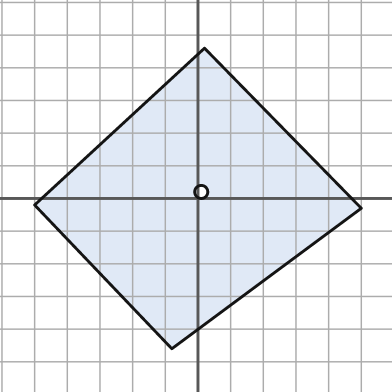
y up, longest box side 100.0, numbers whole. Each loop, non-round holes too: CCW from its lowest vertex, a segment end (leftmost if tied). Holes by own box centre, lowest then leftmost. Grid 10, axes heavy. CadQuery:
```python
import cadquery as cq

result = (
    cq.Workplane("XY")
    .moveTo(-8.0, -46.0)
    .lineTo(50.0, -3.0)
    .lineTo(2.0, 46.0)
    .lineTo(-50.0, -2.0)
    .close()
    .moveTo(1.0, 2.0)
    .circle(2.0)
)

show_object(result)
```